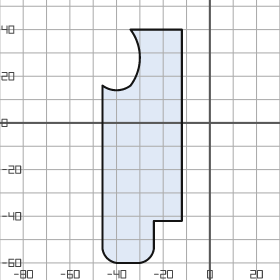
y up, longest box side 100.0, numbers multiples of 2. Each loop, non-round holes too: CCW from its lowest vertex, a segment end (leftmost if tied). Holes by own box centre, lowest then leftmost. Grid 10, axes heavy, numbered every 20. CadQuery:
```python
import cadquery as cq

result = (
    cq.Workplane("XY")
    .moveTo(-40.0, -60.0)
    .lineTo(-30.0, -60.0)
    .threePointArc((-26.0, -58.0), (-24.0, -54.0))
    .lineTo(-24.0, -42.0)
    .lineTo(-12.0, -42.0)
    .lineTo(-12.0, 40.0)
    .lineTo(-34.0, 40.0)
    .threePointArc((-30.0, 28.0), (-34.0, 16.0))
    .threePointArc((-40.0, 14.0), (-46.0, 16.0))
    .lineTo(-46.0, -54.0)
    .threePointArc((-44.0, -58.0), (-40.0, -60.0))
    .close()
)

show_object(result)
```